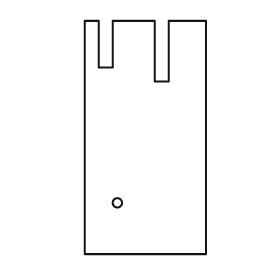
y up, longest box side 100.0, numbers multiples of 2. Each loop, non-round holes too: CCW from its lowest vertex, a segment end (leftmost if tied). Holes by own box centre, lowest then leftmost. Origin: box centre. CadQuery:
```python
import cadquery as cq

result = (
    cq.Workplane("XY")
    .moveTo(-26.0, -50.0)
    .lineTo(26.0, -50.0)
    .lineTo(26.0, 50.0)
    .lineTo(10.0, 50.0)
    .lineTo(10.0, 24.0)
    .lineTo(4.0, 24.0)
    .lineTo(4.0, 50.0)
    .lineTo(-14.0, 50.0)
    .lineTo(-14.0, 30.0)
    .lineTo(-20.0, 30.0)
    .lineTo(-20.0, 50.0)
    .lineTo(-26.0, 50.0)
    .close()
    .moveTo(-12.0, -28.0)
    .circle(2.0)
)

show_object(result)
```